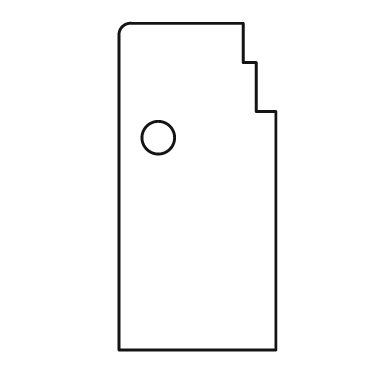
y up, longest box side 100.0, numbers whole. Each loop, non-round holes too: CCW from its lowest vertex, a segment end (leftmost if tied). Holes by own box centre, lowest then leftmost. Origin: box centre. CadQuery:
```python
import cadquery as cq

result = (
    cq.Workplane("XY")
    .moveTo(-24.0, -50.0)
    .lineTo(24.0, -50.0)
    .lineTo(24.0, 23.0)
    .lineTo(18.0, 23.0)
    .lineTo(18.0, 38.0)
    .lineTo(14.0, 38.0)
    .lineTo(14.0, 50.0)
    .lineTo(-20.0, 50.0)
    .threePointArc((-23.0, 49.0), (-24.0, 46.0))
    .close()
    .moveTo(-12.0, 15.0)
    .circle(5.0)
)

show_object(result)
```